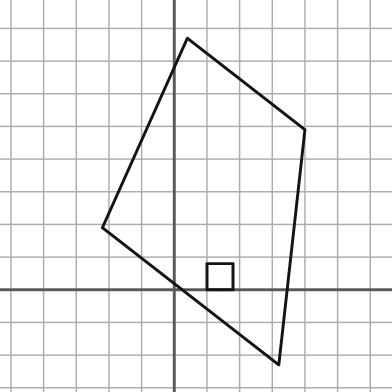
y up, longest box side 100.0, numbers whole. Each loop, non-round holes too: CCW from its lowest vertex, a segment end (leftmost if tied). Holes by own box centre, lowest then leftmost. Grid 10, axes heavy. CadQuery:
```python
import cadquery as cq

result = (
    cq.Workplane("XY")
    .moveTo(32.0, -23.0)
    .lineTo(40.0, 49.0)
    .lineTo(4.0, 77.0)
    .lineTo(-22.0, 19.0)
    .close()
    .moveTo(10.0, 0.0)
    .lineTo(18.0, 0.0)
    .lineTo(18.0, 8.0)
    .lineTo(10.0, 8.0)
    .close()
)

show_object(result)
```